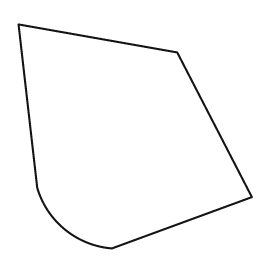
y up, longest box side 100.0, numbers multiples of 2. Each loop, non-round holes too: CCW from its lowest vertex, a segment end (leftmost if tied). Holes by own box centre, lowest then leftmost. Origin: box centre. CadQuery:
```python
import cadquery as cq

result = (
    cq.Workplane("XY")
    .moveTo(-10.0, -48.0)
    .lineTo(50.0, -26.0)
    .lineTo(18.0, 36.0)
    .lineTo(-50.0, 48.0)
    .lineTo(-42.0, -22.0)
    .threePointArc((-30.0, -40.0), (-10.0, -48.0))
    .close()
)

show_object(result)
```